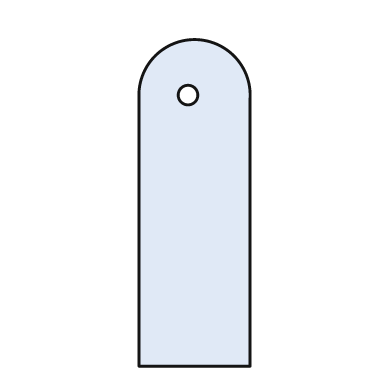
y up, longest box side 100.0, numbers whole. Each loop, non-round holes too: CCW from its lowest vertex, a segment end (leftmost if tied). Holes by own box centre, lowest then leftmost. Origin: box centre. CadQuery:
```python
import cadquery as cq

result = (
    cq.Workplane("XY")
    .moveTo(-17.0, -50.0)
    .lineTo(17.0, -50.0)
    .lineTo(17.0, 32.0)
    .threePointArc((0.0, 50.0), (-17.0, 32.0))
    .close()
    .moveTo(-2.0, 33.0)
    .circle(3.0)
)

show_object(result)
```